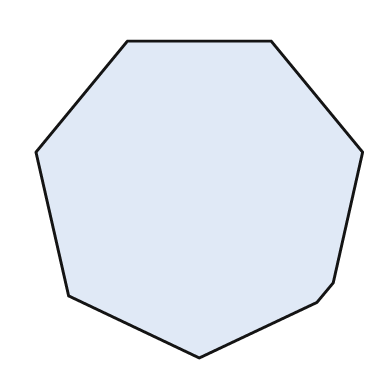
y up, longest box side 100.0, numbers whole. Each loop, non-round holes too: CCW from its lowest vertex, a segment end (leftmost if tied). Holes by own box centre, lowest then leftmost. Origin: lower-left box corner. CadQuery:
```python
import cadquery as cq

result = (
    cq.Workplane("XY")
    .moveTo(50.0, 0.0)
    .lineTo(86.0, 17.0)
    .lineTo(91.0, 23.0)
    .lineTo(100.0, 63.0)
    .lineTo(72.0, 97.0)
    .lineTo(28.0, 97.0)
    .lineTo(0.0, 63.0)
    .lineTo(10.0, 19.0)
    .close()
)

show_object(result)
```